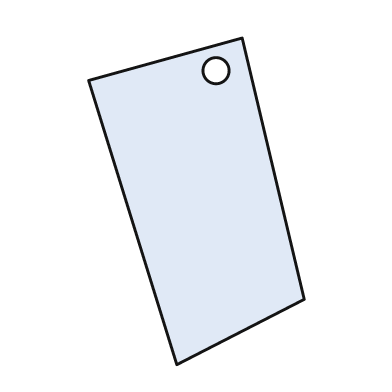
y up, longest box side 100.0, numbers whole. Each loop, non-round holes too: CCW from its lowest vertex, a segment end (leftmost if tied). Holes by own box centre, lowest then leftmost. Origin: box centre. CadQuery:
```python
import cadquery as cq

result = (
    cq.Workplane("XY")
    .moveTo(-6.0, -50.0)
    .lineTo(33.0, -30.0)
    .lineTo(14.0, 50.0)
    .lineTo(-33.0, 37.0)
    .close()
    .moveTo(6.0, 40.0)
    .circle(4.0)
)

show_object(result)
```